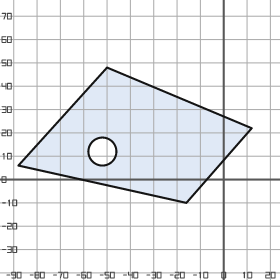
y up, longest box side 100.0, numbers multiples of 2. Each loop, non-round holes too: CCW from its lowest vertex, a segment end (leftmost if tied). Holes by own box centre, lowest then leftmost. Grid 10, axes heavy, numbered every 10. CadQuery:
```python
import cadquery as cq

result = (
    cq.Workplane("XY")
    .moveTo(-16.0, -10.0)
    .lineTo(12.0, 22.0)
    .lineTo(-50.0, 48.0)
    .lineTo(-88.0, 6.0)
    .close()
    .moveTo(-52.0, 12.0)
    .circle(6.0)
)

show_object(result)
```